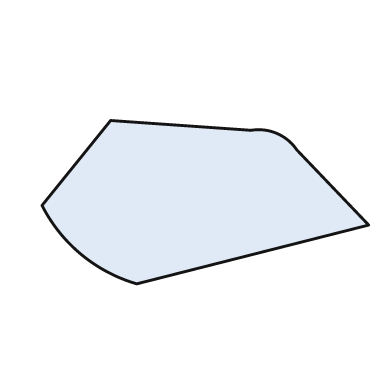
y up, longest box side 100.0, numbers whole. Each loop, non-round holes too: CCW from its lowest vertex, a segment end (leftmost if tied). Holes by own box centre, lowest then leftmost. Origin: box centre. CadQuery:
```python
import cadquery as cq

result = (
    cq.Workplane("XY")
    .moveTo(-21.0, -25.0)
    .lineTo(50.0, -7.0)
    .lineTo(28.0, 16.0)
    .threePointArc((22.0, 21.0), (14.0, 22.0))
    .lineTo(-29.0, 25.0)
    .lineTo(-50.0, -1.0)
    .threePointArc((-38.0, -16.0), (-21.0, -25.0))
    .close()
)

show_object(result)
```